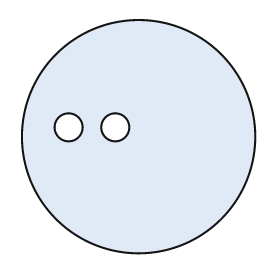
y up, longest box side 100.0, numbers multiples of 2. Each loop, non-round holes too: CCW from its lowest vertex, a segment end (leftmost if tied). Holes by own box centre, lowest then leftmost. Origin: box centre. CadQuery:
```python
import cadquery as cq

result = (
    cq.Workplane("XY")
    .moveTo(0.0, 0.0)
    .circle(50.0)
    .moveTo(-30.0, 4.0)
    .circle(6.0)
    .moveTo(-10.0, 4.0)
    .circle(6.0)
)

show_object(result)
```